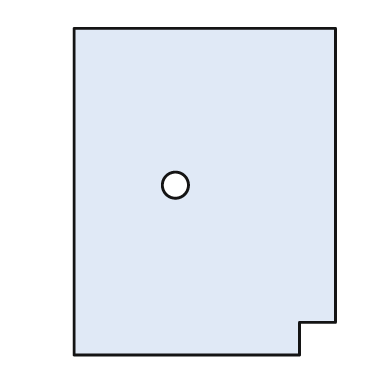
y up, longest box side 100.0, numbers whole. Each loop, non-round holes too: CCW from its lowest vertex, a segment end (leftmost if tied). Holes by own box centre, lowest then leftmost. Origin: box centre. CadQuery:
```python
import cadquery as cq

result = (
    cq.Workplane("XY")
    .moveTo(-40.0, -50.0)
    .lineTo(29.0, -50.0)
    .lineTo(29.0, -40.0)
    .lineTo(40.0, -40.0)
    .lineTo(40.0, 50.0)
    .lineTo(-40.0, 50.0)
    .close()
    .moveTo(-9.0, 2.0)
    .circle(4.0)
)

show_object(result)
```